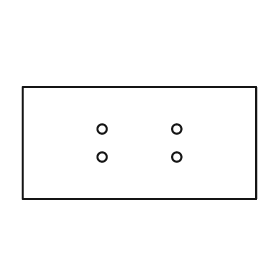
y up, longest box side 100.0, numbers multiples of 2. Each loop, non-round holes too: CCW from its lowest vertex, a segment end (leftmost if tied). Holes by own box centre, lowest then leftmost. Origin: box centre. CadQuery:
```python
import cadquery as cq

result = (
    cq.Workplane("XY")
    .moveTo(-50.0, -24.0)
    .lineTo(50.0, -24.0)
    .lineTo(50.0, 24.0)
    .lineTo(-50.0, 24.0)
    .close()
    .moveTo(-16.0, -6.0)
    .circle(2.0)
    .moveTo(16.0, -6.0)
    .circle(2.0)
    .moveTo(-16.0, 6.0)
    .circle(2.0)
    .moveTo(16.0, 6.0)
    .circle(2.0)
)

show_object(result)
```